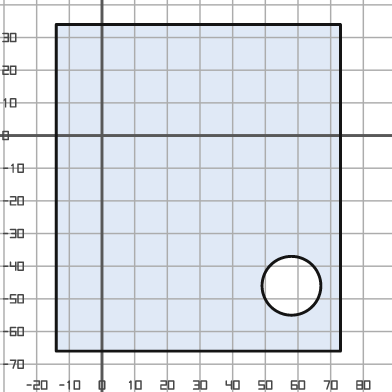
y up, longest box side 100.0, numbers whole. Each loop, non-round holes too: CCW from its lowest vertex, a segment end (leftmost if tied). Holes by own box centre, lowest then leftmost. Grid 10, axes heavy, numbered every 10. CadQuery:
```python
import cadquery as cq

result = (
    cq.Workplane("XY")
    .moveTo(-14.0, -66.0)
    .lineTo(73.0, -66.0)
    .lineTo(73.0, 34.0)
    .lineTo(-14.0, 34.0)
    .close()
    .moveTo(58.0, -46.0)
    .circle(9.0)
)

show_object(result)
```